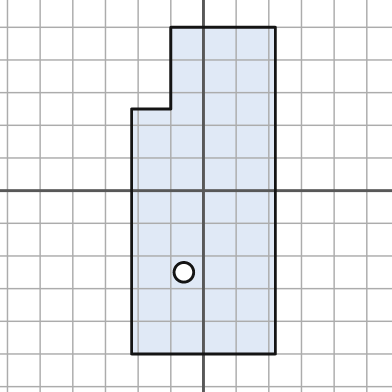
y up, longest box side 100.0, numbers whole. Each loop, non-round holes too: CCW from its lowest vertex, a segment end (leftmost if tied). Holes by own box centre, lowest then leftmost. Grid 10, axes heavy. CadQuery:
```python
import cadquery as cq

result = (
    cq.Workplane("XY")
    .moveTo(-22.0, -50.0)
    .lineTo(22.0, -50.0)
    .lineTo(22.0, 50.0)
    .lineTo(-10.0, 50.0)
    .lineTo(-10.0, 25.0)
    .lineTo(-22.0, 25.0)
    .close()
    .moveTo(-6.0, -25.0)
    .circle(3.0)
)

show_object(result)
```